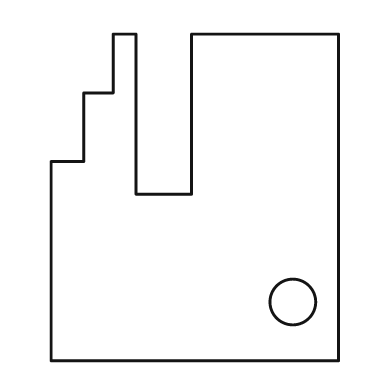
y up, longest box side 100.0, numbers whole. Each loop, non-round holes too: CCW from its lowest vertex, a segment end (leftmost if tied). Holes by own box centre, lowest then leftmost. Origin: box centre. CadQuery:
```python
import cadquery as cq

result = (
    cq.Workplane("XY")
    .moveTo(-44.0, -50.0)
    .lineTo(44.0, -50.0)
    .lineTo(44.0, 50.0)
    .lineTo(-1.0, 50.0)
    .lineTo(-1.0, 1.0)
    .lineTo(-18.0, 1.0)
    .lineTo(-18.0, 50.0)
    .lineTo(-25.0, 50.0)
    .lineTo(-25.0, 32.0)
    .lineTo(-34.0, 32.0)
    .lineTo(-34.0, 11.0)
    .lineTo(-44.0, 11.0)
    .close()
    .moveTo(30.0, -32.0)
    .circle(7.0)
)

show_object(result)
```